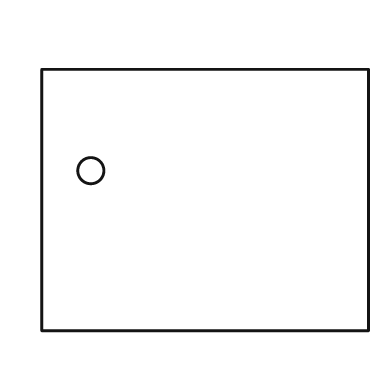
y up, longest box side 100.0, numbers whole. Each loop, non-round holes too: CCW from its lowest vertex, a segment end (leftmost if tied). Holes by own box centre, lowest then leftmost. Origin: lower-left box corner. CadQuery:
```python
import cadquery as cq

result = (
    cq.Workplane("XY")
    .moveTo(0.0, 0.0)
    .lineTo(100.0, 0.0)
    .lineTo(100.0, 80.0)
    .lineTo(0.0, 80.0)
    .close()
    .moveTo(15.0, 49.0)
    .circle(4.0)
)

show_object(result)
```